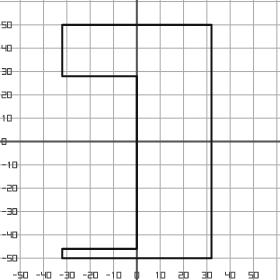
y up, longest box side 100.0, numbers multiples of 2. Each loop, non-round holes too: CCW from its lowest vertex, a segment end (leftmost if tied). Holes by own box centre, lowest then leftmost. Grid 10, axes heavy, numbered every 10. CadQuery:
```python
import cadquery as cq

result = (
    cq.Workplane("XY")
    .moveTo(-32.0, -50.0)
    .lineTo(32.0, -50.0)
    .lineTo(32.0, 50.0)
    .lineTo(-32.0, 50.0)
    .lineTo(-32.0, 28.0)
    .lineTo(0.0, 28.0)
    .lineTo(0.0, -46.0)
    .lineTo(-32.0, -46.0)
    .close()
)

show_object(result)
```